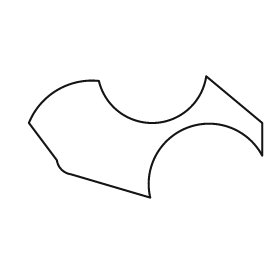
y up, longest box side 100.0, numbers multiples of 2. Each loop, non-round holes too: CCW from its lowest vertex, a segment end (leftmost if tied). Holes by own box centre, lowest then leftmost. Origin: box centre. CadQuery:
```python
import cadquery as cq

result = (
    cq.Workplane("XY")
    .moveTo(2.0, -26.0)
    .threePointArc((18.0, 4.0), (50.0, -8.0))
    .lineTo(50.0, 6.0)
    .lineTo(26.0, 26.0)
    .threePointArc((4.0, 6.0), (-20.0, 24.0))
    .threePointArc((-38.0, 20.0), (-50.0, 6.0))
    .lineTo(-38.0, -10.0)
    .threePointArc((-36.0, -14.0), (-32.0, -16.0))
    .close()
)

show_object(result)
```